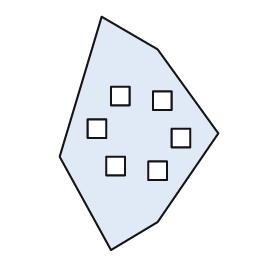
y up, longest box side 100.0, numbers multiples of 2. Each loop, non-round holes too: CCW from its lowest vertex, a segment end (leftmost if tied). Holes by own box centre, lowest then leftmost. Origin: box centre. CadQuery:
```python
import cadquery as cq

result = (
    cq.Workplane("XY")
    .moveTo(-12.0, -50.0)
    .lineTo(8.0, -38.0)
    .lineTo(34.0, 0.0)
    .lineTo(8.0, 36.0)
    .lineTo(-16.0, 50.0)
    .lineTo(-34.0, -10.0)
    .close()
    .moveTo(4.0, -20.0)
    .lineTo(12.0, -20.0)
    .lineTo(12.0, -12.0)
    .lineTo(4.0, -12.0)
    .close()
    .moveTo(-14.0, -18.0)
    .lineTo(-6.0, -18.0)
    .lineTo(-6.0, -10.0)
    .lineTo(-14.0, -10.0)
    .close()
    .moveTo(14.0, -6.0)
    .lineTo(22.0, -6.0)
    .lineTo(22.0, 2.0)
    .lineTo(14.0, 2.0)
    .close()
    .moveTo(-22.0, -2.0)
    .lineTo(-14.0, -2.0)
    .lineTo(-14.0, 6.0)
    .lineTo(-22.0, 6.0)
    .close()
    .moveTo(6.0, 10.0)
    .lineTo(14.0, 10.0)
    .lineTo(14.0, 18.0)
    .lineTo(6.0, 18.0)
    .close()
    .moveTo(-12.0, 12.0)
    .lineTo(-4.0, 12.0)
    .lineTo(-4.0, 20.0)
    .lineTo(-12.0, 20.0)
    .close()
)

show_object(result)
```